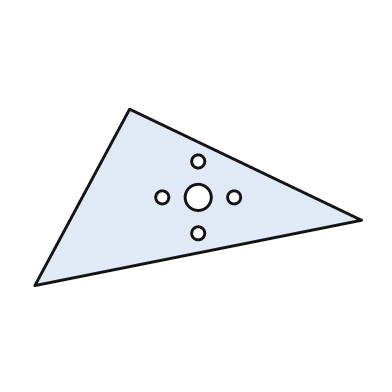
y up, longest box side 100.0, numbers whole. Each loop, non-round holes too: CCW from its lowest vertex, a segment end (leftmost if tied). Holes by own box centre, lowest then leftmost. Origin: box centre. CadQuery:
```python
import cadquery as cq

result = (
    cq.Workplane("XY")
    .moveTo(-50.0, -27.0)
    .lineTo(50.0, -7.0)
    .lineTo(-21.0, 27.0)
    .close()
    .moveTo(0.0, -11.0)
    .circle(2.0)
    .moveTo(-11.0, 0.0)
    .circle(2.0)
    .moveTo(0.0, 0.0)
    .circle(4.0)
    .moveTo(11.0, 0.0)
    .circle(2.0)
    .moveTo(0.0, 11.0)
    .circle(2.0)
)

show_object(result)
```